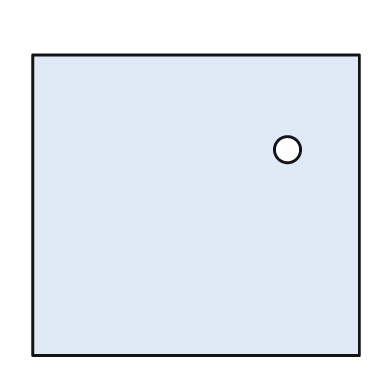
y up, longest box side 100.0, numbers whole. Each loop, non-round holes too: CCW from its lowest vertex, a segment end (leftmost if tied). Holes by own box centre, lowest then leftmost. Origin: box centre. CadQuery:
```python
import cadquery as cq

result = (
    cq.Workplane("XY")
    .moveTo(-50.0, -46.0)
    .lineTo(50.0, -46.0)
    .lineTo(50.0, 46.0)
    .lineTo(-50.0, 46.0)
    .close()
    .moveTo(28.0, 17.0)
    .circle(4.0)
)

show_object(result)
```